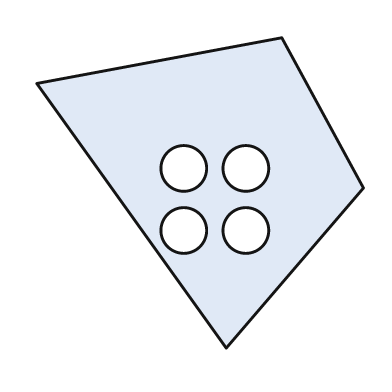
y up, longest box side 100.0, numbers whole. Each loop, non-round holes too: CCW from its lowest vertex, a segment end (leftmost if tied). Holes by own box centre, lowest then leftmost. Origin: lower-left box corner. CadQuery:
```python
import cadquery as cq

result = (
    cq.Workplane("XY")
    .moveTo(58.0, 0.0)
    .lineTo(100.0, 49.0)
    .lineTo(75.0, 95.0)
    .lineTo(0.0, 81.0)
    .close()
    .moveTo(45.0, 36.0)
    .circle(7.0)
    .moveTo(64.0, 36.0)
    .circle(7.0)
    .moveTo(45.0, 55.0)
    .circle(7.0)
    .moveTo(64.0, 55.0)
    .circle(7.0)
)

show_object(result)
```